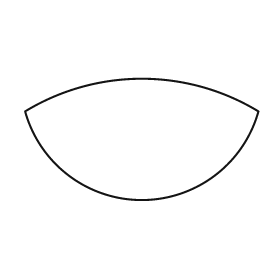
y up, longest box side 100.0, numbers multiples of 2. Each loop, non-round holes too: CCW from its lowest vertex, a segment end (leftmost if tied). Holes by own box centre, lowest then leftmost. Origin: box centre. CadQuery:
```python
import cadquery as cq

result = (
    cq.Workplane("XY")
    .moveTo(-50.0, 12.0)
    .threePointArc((0.0, -26.0), (50.0, 12.0))
    .threePointArc((0.0, 26.0), (-50.0, 12.0))
    .close()
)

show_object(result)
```